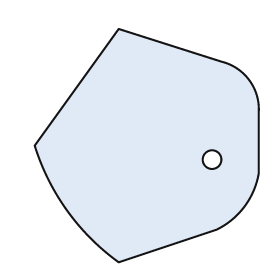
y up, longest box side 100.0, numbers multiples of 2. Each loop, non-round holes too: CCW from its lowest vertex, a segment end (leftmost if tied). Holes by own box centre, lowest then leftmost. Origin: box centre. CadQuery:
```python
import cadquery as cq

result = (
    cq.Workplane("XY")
    .moveTo(-12.0, -50.0)
    .lineTo(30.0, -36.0)
    .threePointArc((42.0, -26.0), (48.0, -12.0))
    .lineTo(48.0, 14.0)
    .threePointArc((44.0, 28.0), (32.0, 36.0))
    .lineTo(-12.0, 50.0)
    .lineTo(-48.0, 0.0)
    .threePointArc((-34.0, -28.0), (-12.0, -50.0))
    .close()
    .moveTo(28.0, -6.0)
    .circle(4.0)
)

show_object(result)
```